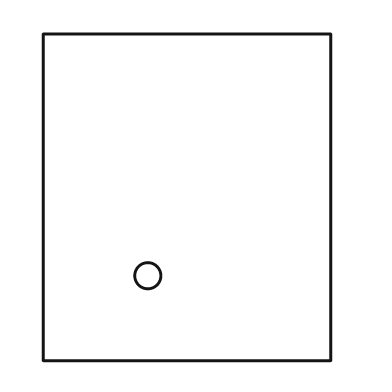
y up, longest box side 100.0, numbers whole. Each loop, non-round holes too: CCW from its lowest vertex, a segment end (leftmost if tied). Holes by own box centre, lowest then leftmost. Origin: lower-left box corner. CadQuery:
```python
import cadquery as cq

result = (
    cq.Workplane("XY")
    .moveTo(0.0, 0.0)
    .lineTo(88.0, 0.0)
    .lineTo(88.0, 100.0)
    .lineTo(0.0, 100.0)
    .close()
    .moveTo(32.0, 26.0)
    .circle(4.0)
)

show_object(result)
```